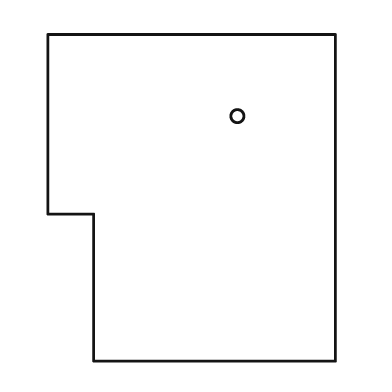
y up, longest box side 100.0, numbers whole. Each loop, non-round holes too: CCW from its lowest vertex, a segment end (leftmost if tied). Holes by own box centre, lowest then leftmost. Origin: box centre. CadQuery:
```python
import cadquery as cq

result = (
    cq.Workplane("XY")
    .moveTo(-30.0, -50.0)
    .lineTo(44.0, -50.0)
    .lineTo(44.0, 50.0)
    .lineTo(-44.0, 50.0)
    .lineTo(-44.0, -5.0)
    .lineTo(-30.0, -5.0)
    .close()
    .moveTo(14.0, 25.0)
    .circle(2.0)
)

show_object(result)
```